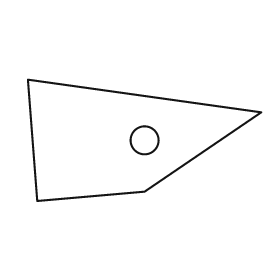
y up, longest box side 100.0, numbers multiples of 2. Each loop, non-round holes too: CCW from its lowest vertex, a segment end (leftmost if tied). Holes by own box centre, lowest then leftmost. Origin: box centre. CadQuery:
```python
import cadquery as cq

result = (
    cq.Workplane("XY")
    .moveTo(-46.0, -26.0)
    .lineTo(0.0, -22.0)
    .lineTo(50.0, 12.0)
    .lineTo(-50.0, 26.0)
    .close()
    .moveTo(0.0, 0.0)
    .circle(6.0)
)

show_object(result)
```